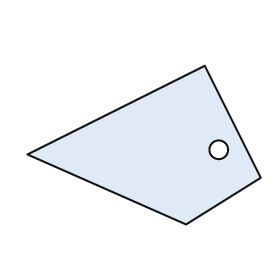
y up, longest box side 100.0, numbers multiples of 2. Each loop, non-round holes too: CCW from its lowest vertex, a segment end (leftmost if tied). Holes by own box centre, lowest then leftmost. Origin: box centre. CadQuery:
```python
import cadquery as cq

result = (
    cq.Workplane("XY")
    .moveTo(18.0, -34.0)
    .lineTo(50.0, -14.0)
    .lineTo(26.0, 34.0)
    .lineTo(-50.0, -4.0)
    .close()
    .moveTo(32.0, -2.0)
    .circle(4.0)
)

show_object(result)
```